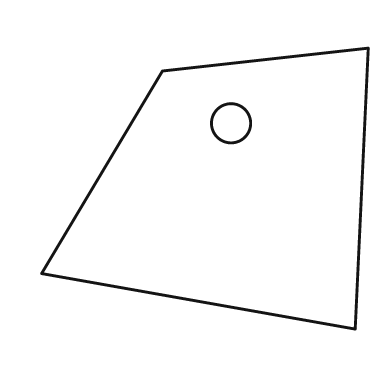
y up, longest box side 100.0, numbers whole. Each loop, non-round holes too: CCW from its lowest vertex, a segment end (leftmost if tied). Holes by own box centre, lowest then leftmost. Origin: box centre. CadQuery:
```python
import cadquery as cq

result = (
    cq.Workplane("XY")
    .moveTo(46.0, -43.0)
    .lineTo(50.0, 43.0)
    .lineTo(-13.0, 36.0)
    .lineTo(-50.0, -26.0)
    .close()
    .moveTo(8.0, 20.0)
    .circle(6.0)
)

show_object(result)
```